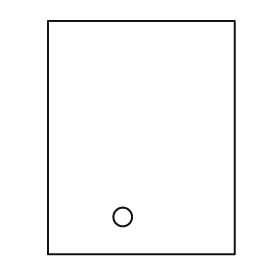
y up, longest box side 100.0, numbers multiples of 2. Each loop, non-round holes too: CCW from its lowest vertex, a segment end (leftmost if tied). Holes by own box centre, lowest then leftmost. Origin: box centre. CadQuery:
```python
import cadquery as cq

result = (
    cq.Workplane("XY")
    .moveTo(-40.0, -50.0)
    .lineTo(40.0, -50.0)
    .lineTo(40.0, 50.0)
    .lineTo(-40.0, 50.0)
    .close()
    .moveTo(-8.0, -34.0)
    .circle(4.0)
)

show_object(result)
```